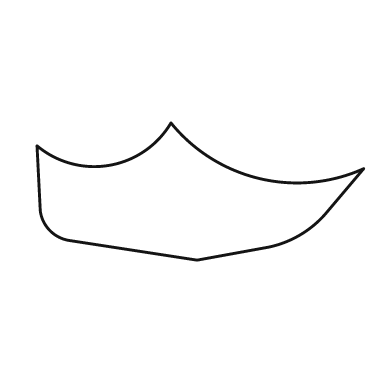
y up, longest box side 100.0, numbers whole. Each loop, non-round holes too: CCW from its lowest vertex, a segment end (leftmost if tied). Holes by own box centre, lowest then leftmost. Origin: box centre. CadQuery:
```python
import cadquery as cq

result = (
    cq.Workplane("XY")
    .moveTo(-1.0, -21.0)
    .lineTo(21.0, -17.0)
    .threePointArc((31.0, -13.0), (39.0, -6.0))
    .lineTo(50.0, 7.0)
    .threePointArc((18.0, 4.0), (-9.0, 21.0))
    .threePointArc((-28.0, 8.0), (-50.0, 14.0))
    .lineTo(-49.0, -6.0)
    .threePointArc((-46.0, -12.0), (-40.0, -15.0))
    .close()
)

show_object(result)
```